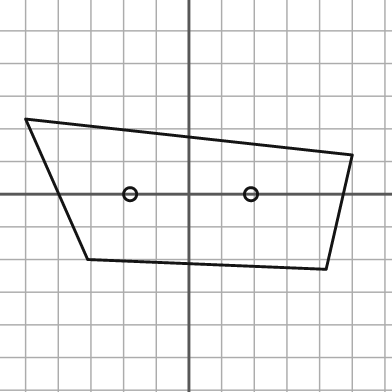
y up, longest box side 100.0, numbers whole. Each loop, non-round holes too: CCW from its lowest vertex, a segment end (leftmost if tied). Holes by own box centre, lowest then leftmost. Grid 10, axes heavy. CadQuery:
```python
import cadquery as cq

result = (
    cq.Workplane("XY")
    .moveTo(42.0, -23.0)
    .lineTo(50.0, 12.0)
    .lineTo(-50.0, 23.0)
    .lineTo(-31.0, -20.0)
    .close()
    .moveTo(-18.0, 0.0)
    .circle(2.0)
    .moveTo(19.0, 0.0)
    .circle(2.0)
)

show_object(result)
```